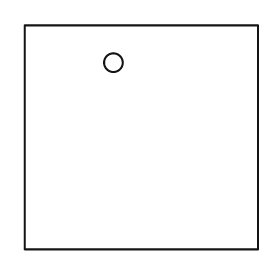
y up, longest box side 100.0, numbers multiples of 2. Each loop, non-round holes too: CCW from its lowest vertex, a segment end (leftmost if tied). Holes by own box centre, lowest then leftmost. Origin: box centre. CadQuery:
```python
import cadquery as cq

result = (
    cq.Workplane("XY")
    .moveTo(-50.0, -48.0)
    .lineTo(50.0, -48.0)
    .lineTo(50.0, 48.0)
    .lineTo(-50.0, 48.0)
    .close()
    .moveTo(-12.0, 32.0)
    .circle(4.0)
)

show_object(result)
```